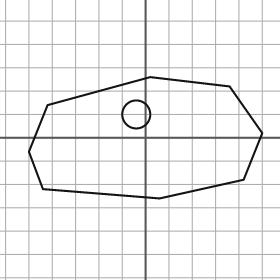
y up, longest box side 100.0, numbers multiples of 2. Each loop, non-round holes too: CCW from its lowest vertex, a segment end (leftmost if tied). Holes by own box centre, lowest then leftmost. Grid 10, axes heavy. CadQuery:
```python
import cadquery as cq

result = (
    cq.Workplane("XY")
    .moveTo(6.0, -26.0)
    .lineTo(42.0, -18.0)
    .lineTo(50.0, 2.0)
    .lineTo(36.0, 22.0)
    .lineTo(2.0, 26.0)
    .lineTo(-42.0, 14.0)
    .lineTo(-50.0, -6.0)
    .lineTo(-44.0, -22.0)
    .close()
    .moveTo(-4.0, 10.0)
    .circle(6.0)
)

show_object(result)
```